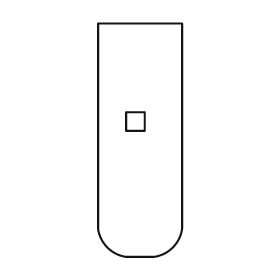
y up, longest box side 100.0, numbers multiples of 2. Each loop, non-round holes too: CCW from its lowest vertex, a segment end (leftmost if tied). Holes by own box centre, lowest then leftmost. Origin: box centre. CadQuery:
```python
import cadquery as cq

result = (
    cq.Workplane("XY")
    .moveTo(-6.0, -50.0)
    .lineTo(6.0, -50.0)
    .threePointArc((14.0, -46.0), (18.0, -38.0))
    .lineTo(18.0, 50.0)
    .lineTo(-18.0, 50.0)
    .lineTo(-18.0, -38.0)
    .threePointArc((-14.0, -46.0), (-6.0, -50.0))
    .close()
    .moveTo(-6.0, 4.0)
    .lineTo(2.0, 4.0)
    .lineTo(2.0, 12.0)
    .lineTo(-6.0, 12.0)
    .close()
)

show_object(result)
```